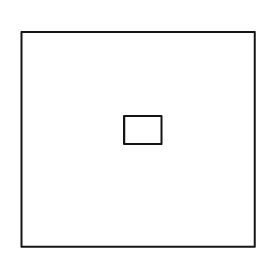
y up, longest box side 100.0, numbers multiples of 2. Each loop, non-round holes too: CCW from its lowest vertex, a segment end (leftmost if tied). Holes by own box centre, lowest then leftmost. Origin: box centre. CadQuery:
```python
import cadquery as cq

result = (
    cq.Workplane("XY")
    .moveTo(-50.0, -46.0)
    .lineTo(50.0, -46.0)
    .lineTo(50.0, 46.0)
    .lineTo(-50.0, 46.0)
    .close()
    .moveTo(-6.0, -2.0)
    .lineTo(10.0, -2.0)
    .lineTo(10.0, 10.0)
    .lineTo(-6.0, 10.0)
    .close()
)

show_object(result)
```